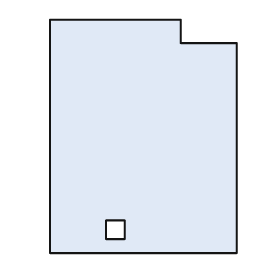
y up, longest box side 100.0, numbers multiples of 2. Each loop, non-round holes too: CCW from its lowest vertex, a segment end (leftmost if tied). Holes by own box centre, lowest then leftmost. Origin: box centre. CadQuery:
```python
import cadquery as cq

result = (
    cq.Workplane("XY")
    .moveTo(-40.0, -50.0)
    .lineTo(40.0, -50.0)
    .lineTo(40.0, 40.0)
    .lineTo(16.0, 40.0)
    .lineTo(16.0, 50.0)
    .lineTo(-40.0, 50.0)
    .close()
    .moveTo(-16.0, -44.0)
    .lineTo(-8.0, -44.0)
    .lineTo(-8.0, -36.0)
    .lineTo(-16.0, -36.0)
    .close()
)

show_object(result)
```